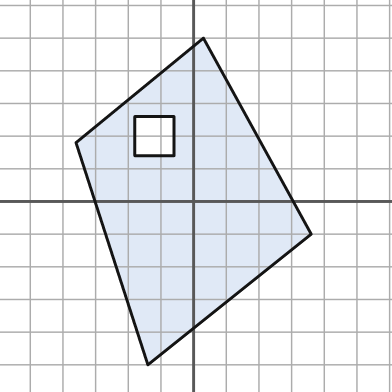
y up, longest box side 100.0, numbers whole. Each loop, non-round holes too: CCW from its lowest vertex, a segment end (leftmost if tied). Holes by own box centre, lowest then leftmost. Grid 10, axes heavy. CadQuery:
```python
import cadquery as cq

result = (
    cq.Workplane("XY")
    .moveTo(-14.0, -50.0)
    .lineTo(36.0, -10.0)
    .lineTo(3.0, 50.0)
    .lineTo(-36.0, 18.0)
    .close()
    .moveTo(-18.0, 14.0)
    .lineTo(-6.0, 14.0)
    .lineTo(-6.0, 26.0)
    .lineTo(-18.0, 26.0)
    .close()
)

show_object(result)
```